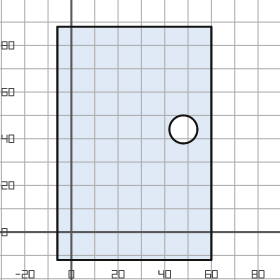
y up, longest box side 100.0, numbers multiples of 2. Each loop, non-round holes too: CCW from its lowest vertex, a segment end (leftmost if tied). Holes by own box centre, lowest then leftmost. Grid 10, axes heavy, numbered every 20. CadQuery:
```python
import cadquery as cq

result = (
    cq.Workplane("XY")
    .moveTo(-6.0, -12.0)
    .lineTo(60.0, -12.0)
    .lineTo(60.0, 88.0)
    .lineTo(-6.0, 88.0)
    .close()
    .moveTo(48.0, 44.0)
    .circle(6.0)
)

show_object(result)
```